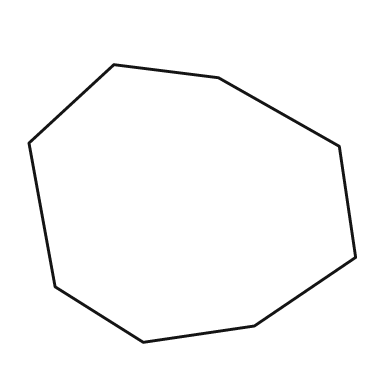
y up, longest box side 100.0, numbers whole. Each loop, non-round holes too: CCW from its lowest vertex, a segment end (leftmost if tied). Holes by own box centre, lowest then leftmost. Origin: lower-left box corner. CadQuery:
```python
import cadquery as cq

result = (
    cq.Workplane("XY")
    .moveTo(35.0, 0.0)
    .lineTo(69.0, 5.0)
    .lineTo(100.0, 26.0)
    .lineTo(95.0, 60.0)
    .lineTo(58.0, 81.0)
    .lineTo(26.0, 85.0)
    .lineTo(0.0, 61.0)
    .lineTo(8.0, 17.0)
    .close()
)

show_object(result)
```